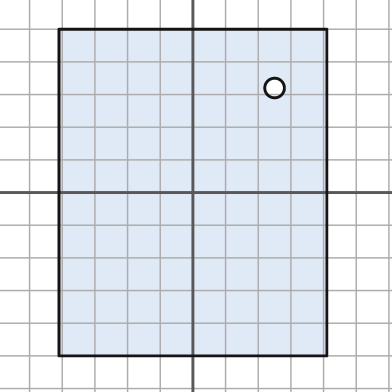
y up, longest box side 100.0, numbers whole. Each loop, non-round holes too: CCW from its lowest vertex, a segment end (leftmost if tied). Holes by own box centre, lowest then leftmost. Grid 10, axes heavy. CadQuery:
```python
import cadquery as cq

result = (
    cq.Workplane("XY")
    .moveTo(-41.0, -50.0)
    .lineTo(41.0, -50.0)
    .lineTo(41.0, 50.0)
    .lineTo(-41.0, 50.0)
    .close()
    .moveTo(25.0, 32.0)
    .circle(3.0)
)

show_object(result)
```